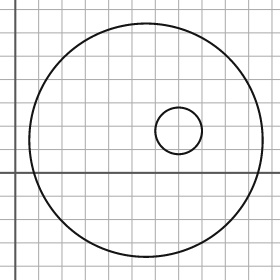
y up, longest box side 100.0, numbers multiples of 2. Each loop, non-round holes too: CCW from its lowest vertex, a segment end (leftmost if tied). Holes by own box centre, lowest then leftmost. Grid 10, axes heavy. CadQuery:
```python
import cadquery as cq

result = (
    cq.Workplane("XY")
    .moveTo(56.0, 14.0)
    .circle(50.0)
    .moveTo(70.0, 18.0)
    .circle(10.0)
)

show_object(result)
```